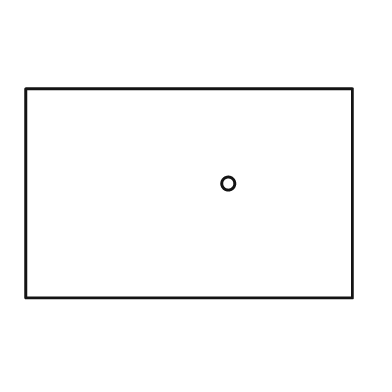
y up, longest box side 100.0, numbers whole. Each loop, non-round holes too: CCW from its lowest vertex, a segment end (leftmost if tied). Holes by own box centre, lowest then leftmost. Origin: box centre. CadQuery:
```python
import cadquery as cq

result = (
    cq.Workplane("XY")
    .moveTo(-50.0, -32.0)
    .lineTo(50.0, -32.0)
    .lineTo(50.0, 32.0)
    .lineTo(-50.0, 32.0)
    .close()
    .moveTo(12.0, 3.0)
    .circle(2.0)
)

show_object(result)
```